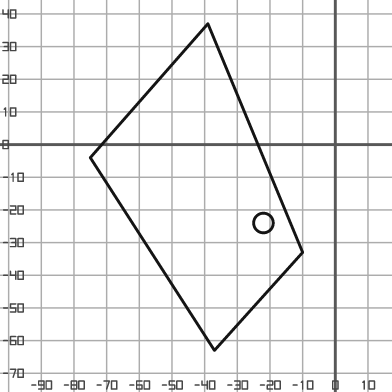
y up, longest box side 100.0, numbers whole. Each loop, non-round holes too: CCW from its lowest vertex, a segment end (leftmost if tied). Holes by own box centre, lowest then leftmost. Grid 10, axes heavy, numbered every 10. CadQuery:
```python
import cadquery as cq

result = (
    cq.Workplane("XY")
    .moveTo(-37.0, -63.0)
    .lineTo(-10.0, -33.0)
    .lineTo(-39.0, 37.0)
    .lineTo(-75.0, -4.0)
    .close()
    .moveTo(-22.0, -24.0)
    .circle(3.0)
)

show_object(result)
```